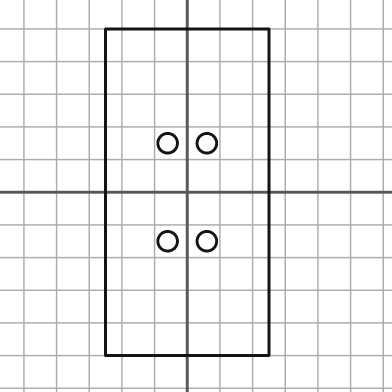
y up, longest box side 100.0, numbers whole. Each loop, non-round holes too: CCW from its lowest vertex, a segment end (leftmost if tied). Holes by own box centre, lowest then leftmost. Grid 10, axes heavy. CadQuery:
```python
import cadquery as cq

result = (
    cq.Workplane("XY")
    .moveTo(-25.0, -50.0)
    .lineTo(25.0, -50.0)
    .lineTo(25.0, 50.0)
    .lineTo(-25.0, 50.0)
    .close()
    .moveTo(-6.0, -15.0)
    .circle(3.0)
    .moveTo(6.0, -15.0)
    .circle(3.0)
    .moveTo(-6.0, 15.0)
    .circle(3.0)
    .moveTo(6.0, 15.0)
    .circle(3.0)
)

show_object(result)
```